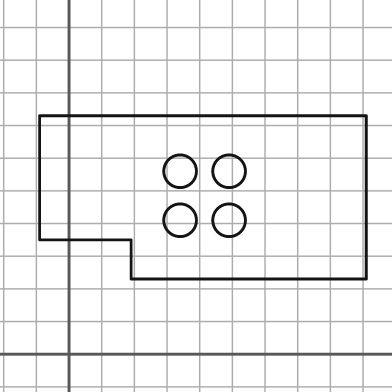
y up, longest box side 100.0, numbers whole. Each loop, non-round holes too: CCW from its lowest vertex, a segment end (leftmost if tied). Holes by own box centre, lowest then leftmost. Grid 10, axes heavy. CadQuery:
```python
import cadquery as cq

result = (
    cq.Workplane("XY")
    .moveTo(19.0, 23.0)
    .lineTo(91.0, 23.0)
    .lineTo(91.0, 73.0)
    .lineTo(-9.0, 73.0)
    .lineTo(-9.0, 35.0)
    .lineTo(19.0, 35.0)
    .close()
    .moveTo(34.0, 41.0)
    .circle(5.0)
    .moveTo(49.0, 41.0)
    .circle(5.0)
    .moveTo(34.0, 56.0)
    .circle(5.0)
    .moveTo(49.0, 56.0)
    .circle(5.0)
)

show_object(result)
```